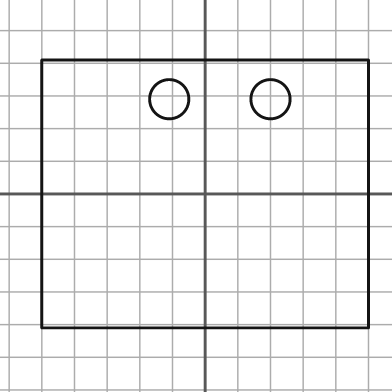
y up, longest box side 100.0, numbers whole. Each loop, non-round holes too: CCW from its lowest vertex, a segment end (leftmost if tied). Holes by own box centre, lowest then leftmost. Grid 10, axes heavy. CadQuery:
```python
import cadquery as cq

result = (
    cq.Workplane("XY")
    .moveTo(-50.0, -41.0)
    .lineTo(50.0, -41.0)
    .lineTo(50.0, 41.0)
    .lineTo(-50.0, 41.0)
    .close()
    .moveTo(-11.0, 29.0)
    .circle(6.0)
    .moveTo(20.0, 29.0)
    .circle(6.0)
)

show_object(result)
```